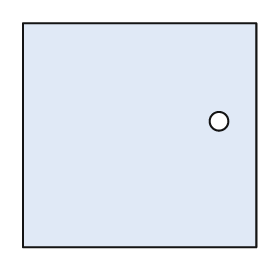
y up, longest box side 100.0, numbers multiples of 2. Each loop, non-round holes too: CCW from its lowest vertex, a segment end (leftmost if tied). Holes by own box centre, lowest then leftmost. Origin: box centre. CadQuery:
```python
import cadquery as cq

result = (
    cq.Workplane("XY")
    .moveTo(-50.0, -48.0)
    .lineTo(50.0, -48.0)
    .lineTo(50.0, 48.0)
    .lineTo(-50.0, 48.0)
    .close()
    .moveTo(34.0, 6.0)
    .circle(4.0)
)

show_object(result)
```